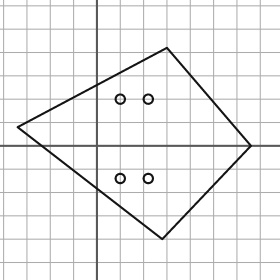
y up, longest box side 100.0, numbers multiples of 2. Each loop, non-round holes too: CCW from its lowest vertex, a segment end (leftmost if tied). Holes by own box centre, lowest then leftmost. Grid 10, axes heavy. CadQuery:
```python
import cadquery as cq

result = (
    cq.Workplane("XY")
    .moveTo(28.0, -40.0)
    .lineTo(66.0, 0.0)
    .lineTo(30.0, 42.0)
    .lineTo(-34.0, 8.0)
    .close()
    .moveTo(10.0, -14.0)
    .circle(2.0)
    .moveTo(22.0, -14.0)
    .circle(2.0)
    .moveTo(10.0, 20.0)
    .circle(2.0)
    .moveTo(22.0, 20.0)
    .circle(2.0)
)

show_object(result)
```